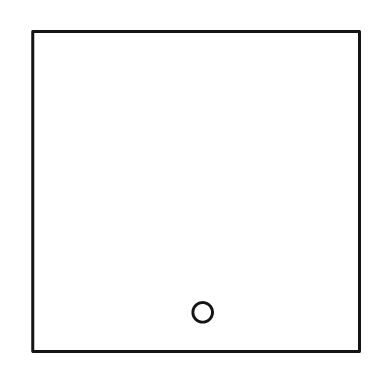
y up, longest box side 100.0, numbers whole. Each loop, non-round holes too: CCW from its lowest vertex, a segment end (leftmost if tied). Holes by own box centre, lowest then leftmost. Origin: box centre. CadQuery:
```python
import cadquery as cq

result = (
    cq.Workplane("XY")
    .moveTo(-50.0, -49.0)
    .lineTo(50.0, -49.0)
    .lineTo(50.0, 49.0)
    .lineTo(-50.0, 49.0)
    .close()
    .moveTo(2.0, -37.0)
    .circle(3.0)
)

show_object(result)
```